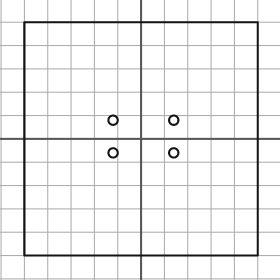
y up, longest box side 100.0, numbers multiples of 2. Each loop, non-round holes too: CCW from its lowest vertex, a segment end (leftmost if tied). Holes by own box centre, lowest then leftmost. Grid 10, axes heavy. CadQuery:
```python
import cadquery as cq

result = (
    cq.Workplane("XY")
    .moveTo(-50.0, -50.0)
    .lineTo(50.0, -50.0)
    .lineTo(50.0, 50.0)
    .lineTo(-50.0, 50.0)
    .close()
    .moveTo(-12.0, -6.0)
    .circle(2.0)
    .moveTo(14.0, -6.0)
    .circle(2.0)
    .moveTo(-12.0, 8.0)
    .circle(2.0)
    .moveTo(14.0, 8.0)
    .circle(2.0)
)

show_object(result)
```